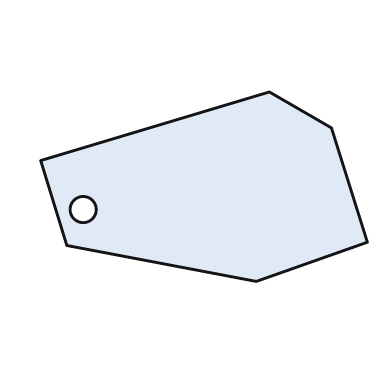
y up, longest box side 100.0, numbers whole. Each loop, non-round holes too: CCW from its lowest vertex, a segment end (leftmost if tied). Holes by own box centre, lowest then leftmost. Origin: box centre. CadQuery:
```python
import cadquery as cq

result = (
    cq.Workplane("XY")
    .moveTo(16.0, -29.0)
    .lineTo(50.0, -17.0)
    .lineTo(39.0, 18.0)
    .lineTo(20.0, 29.0)
    .lineTo(-50.0, 8.0)
    .lineTo(-42.0, -18.0)
    .close()
    .moveTo(-37.0, -7.0)
    .circle(4.0)
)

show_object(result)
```